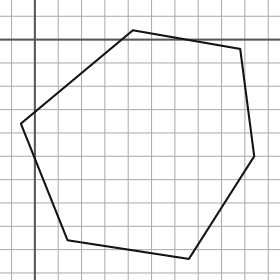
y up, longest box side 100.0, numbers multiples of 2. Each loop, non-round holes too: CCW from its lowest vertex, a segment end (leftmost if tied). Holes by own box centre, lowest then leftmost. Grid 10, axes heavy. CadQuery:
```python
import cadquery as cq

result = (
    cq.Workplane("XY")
    .moveTo(66.0, -94.0)
    .lineTo(94.0, -50.0)
    .lineTo(88.0, -4.0)
    .lineTo(42.0, 4.0)
    .lineTo(-6.0, -36.0)
    .lineTo(14.0, -86.0)
    .close()
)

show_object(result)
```